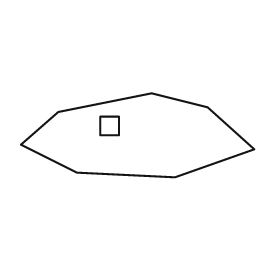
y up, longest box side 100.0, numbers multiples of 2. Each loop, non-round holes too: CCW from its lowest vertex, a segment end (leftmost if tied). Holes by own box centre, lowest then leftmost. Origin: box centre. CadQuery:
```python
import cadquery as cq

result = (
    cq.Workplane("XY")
    .moveTo(16.0, -18.0)
    .lineTo(50.0, -6.0)
    .lineTo(30.0, 12.0)
    .lineTo(6.0, 18.0)
    .lineTo(-34.0, 10.0)
    .lineTo(-50.0, -4.0)
    .lineTo(-26.0, -16.0)
    .close()
    .moveTo(-16.0, 0.0)
    .lineTo(-8.0, 0.0)
    .lineTo(-8.0, 8.0)
    .lineTo(-16.0, 8.0)
    .close()
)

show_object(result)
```